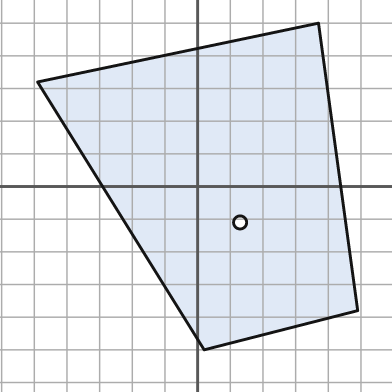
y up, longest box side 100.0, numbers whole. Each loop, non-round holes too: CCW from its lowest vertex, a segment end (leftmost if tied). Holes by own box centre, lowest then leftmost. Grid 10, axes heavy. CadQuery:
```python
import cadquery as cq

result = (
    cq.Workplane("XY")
    .moveTo(2.0, -50.0)
    .lineTo(49.0, -38.0)
    .lineTo(37.0, 50.0)
    .lineTo(-49.0, 32.0)
    .close()
    .moveTo(13.0, -11.0)
    .circle(2.0)
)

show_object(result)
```